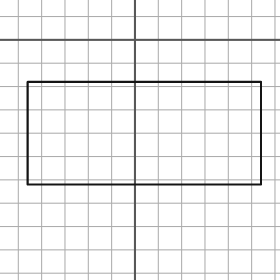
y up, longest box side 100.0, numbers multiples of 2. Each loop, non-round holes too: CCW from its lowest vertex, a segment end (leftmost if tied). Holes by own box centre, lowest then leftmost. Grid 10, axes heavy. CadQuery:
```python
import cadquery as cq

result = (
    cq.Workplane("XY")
    .moveTo(-46.0, -62.0)
    .lineTo(54.0, -62.0)
    .lineTo(54.0, -18.0)
    .lineTo(-46.0, -18.0)
    .close()
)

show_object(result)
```